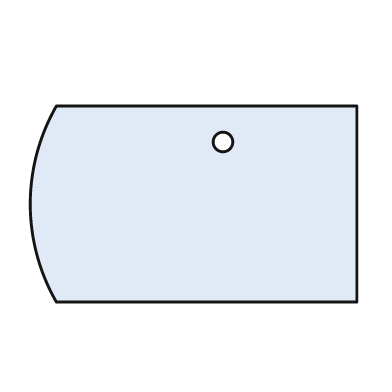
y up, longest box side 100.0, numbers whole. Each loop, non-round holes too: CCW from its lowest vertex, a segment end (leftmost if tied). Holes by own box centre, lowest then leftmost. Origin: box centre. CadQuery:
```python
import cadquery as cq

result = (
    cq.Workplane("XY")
    .moveTo(-42.0, -30.0)
    .lineTo(50.0, -30.0)
    .lineTo(50.0, 30.0)
    .lineTo(-42.0, 30.0)
    .threePointArc((-50.0, 0.0), (-42.0, -30.0))
    .close()
    .moveTo(9.0, 19.0)
    .circle(3.0)
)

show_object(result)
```